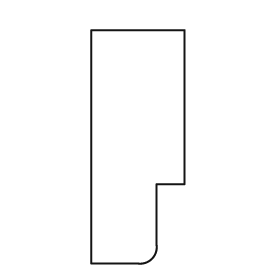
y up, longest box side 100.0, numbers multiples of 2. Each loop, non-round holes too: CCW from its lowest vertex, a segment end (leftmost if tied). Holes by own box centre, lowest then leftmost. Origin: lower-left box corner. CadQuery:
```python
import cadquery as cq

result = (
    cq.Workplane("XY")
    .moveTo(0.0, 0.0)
    .lineTo(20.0, 0.0)
    .threePointArc((26.0, 2.0), (28.0, 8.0))
    .lineTo(28.0, 34.0)
    .lineTo(40.0, 34.0)
    .lineTo(40.0, 100.0)
    .lineTo(0.0, 100.0)
    .close()
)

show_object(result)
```